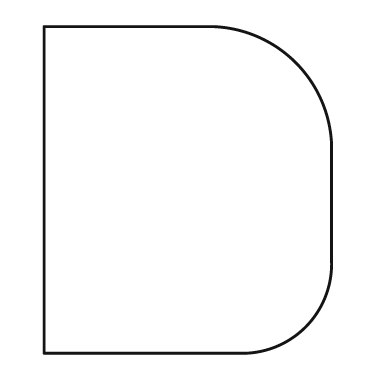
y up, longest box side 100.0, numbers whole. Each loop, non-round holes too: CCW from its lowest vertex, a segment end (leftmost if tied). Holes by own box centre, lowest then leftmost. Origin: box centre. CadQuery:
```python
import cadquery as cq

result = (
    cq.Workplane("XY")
    .moveTo(-44.0, -50.0)
    .lineTo(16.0, -50.0)
    .threePointArc((36.0, -42.0), (44.0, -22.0))
    .lineTo(44.0, 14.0)
    .threePointArc((33.0, 39.0), (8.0, 50.0))
    .lineTo(-44.0, 50.0)
    .close()
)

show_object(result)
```